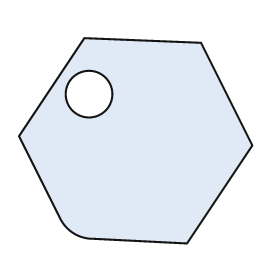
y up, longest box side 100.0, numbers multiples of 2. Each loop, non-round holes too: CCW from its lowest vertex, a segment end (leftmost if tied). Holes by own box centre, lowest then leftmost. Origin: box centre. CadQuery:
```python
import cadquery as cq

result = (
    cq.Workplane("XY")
    .moveTo(22.0, -44.0)
    .lineTo(50.0, -2.0)
    .lineTo(28.0, 42.0)
    .lineTo(-22.0, 44.0)
    .lineTo(-50.0, 2.0)
    .lineTo(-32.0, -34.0)
    .threePointArc((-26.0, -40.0), (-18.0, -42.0))
    .close()
    .moveTo(-20.0, 20.0)
    .circle(10.0)
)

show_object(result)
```